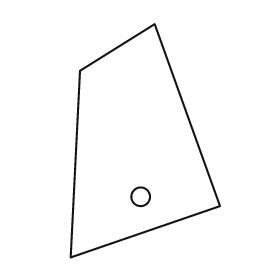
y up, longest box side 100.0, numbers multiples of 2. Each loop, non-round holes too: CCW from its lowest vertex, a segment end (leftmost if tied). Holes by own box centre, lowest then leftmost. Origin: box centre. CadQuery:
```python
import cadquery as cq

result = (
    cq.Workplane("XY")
    .moveTo(-32.0, -50.0)
    .lineTo(32.0, -28.0)
    .lineTo(4.0, 50.0)
    .lineTo(-28.0, 30.0)
    .close()
    .moveTo(-2.0, -24.0)
    .circle(4.0)
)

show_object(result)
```